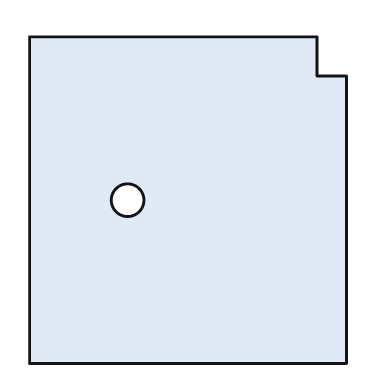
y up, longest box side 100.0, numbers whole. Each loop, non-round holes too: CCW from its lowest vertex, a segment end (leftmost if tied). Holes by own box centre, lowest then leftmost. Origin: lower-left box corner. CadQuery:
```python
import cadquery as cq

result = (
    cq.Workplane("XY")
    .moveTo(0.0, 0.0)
    .lineTo(97.0, 0.0)
    .lineTo(97.0, 88.0)
    .lineTo(88.0, 88.0)
    .lineTo(88.0, 100.0)
    .lineTo(0.0, 100.0)
    .close()
    .moveTo(30.0, 50.0)
    .circle(5.0)
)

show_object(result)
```